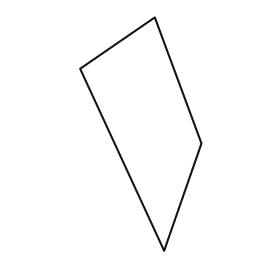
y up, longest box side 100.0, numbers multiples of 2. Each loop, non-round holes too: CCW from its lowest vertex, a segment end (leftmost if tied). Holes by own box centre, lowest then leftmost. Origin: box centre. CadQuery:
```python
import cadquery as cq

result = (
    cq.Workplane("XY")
    .moveTo(10.0, -50.0)
    .lineTo(26.0, -4.0)
    .lineTo(6.0, 50.0)
    .lineTo(-26.0, 28.0)
    .close()
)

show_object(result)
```